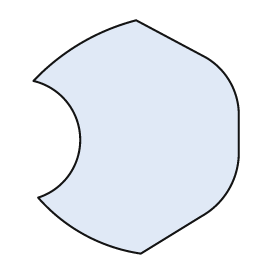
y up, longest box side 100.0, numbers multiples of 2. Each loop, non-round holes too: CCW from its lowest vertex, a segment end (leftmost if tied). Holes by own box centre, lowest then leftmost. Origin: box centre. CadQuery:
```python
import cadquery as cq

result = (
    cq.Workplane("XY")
    .moveTo(2.0, -50.0)
    .lineTo(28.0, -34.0)
    .threePointArc((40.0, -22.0), (44.0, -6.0))
    .lineTo(44.0, 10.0)
    .threePointArc((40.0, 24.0), (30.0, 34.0))
    .lineTo(0.0, 50.0)
    .threePointArc((-24.0, 40.0), (-44.0, 24.0))
    .threePointArc((-24.0, 0.0), (-42.0, -26.0))
    .threePointArc((-22.0, -42.0), (2.0, -50.0))
    .close()
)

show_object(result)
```